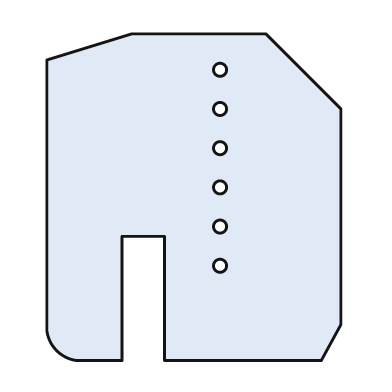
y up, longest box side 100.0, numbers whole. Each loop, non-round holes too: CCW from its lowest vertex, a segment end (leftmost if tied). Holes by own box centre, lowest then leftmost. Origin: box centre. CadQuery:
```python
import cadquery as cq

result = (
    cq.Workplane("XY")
    .moveTo(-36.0, -50.0)
    .lineTo(-22.0, -50.0)
    .lineTo(-22.0, -12.0)
    .lineTo(-9.0, -12.0)
    .lineTo(-9.0, -50.0)
    .lineTo(39.0, -50.0)
    .lineTo(45.0, -39.0)
    .lineTo(45.0, 27.0)
    .lineTo(22.0, 50.0)
    .lineTo(-19.0, 50.0)
    .lineTo(-45.0, 42.0)
    .lineTo(-45.0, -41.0)
    .threePointArc((-42.0, -47.0), (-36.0, -50.0))
    .close()
    .moveTo(8.0, -21.0)
    .circle(2.0)
    .moveTo(8.0, -9.0)
    .circle(2.0)
    .moveTo(8.0, 3.0)
    .circle(2.0)
    .moveTo(8.0, 15.0)
    .circle(2.0)
    .moveTo(8.0, 27.0)
    .circle(2.0)
    .moveTo(8.0, 39.0)
    .circle(2.0)
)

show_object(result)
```